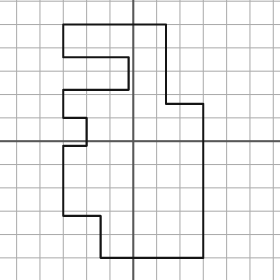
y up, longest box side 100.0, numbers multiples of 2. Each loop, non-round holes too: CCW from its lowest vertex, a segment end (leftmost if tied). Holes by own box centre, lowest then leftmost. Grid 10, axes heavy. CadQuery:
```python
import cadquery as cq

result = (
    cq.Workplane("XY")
    .moveTo(-14.0, -50.0)
    .lineTo(30.0, -50.0)
    .lineTo(30.0, 16.0)
    .lineTo(14.0, 16.0)
    .lineTo(14.0, 50.0)
    .lineTo(-30.0, 50.0)
    .lineTo(-30.0, 36.0)
    .lineTo(-2.0, 36.0)
    .lineTo(-2.0, 22.0)
    .lineTo(-30.0, 22.0)
    .lineTo(-30.0, 10.0)
    .lineTo(-20.0, 10.0)
    .lineTo(-20.0, -2.0)
    .lineTo(-30.0, -2.0)
    .lineTo(-30.0, -32.0)
    .lineTo(-14.0, -32.0)
    .close()
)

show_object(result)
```